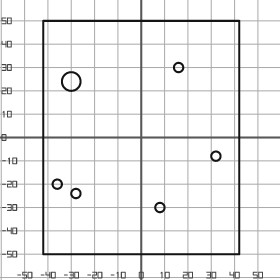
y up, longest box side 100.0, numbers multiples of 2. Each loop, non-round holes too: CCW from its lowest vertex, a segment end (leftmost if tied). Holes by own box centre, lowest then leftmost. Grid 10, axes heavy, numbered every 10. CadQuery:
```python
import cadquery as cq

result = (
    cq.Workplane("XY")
    .moveTo(-42.0, -50.0)
    .lineTo(42.0, -50.0)
    .lineTo(42.0, 50.0)
    .lineTo(-42.0, 50.0)
    .close()
    .moveTo(8.0, -30.0)
    .circle(2.0)
    .moveTo(-28.0, -24.0)
    .circle(2.0)
    .moveTo(-36.0, -20.0)
    .circle(2.0)
    .moveTo(32.0, -8.0)
    .circle(2.0)
    .moveTo(-30.0, 24.0)
    .circle(4.0)
    .moveTo(16.0, 30.0)
    .circle(2.0)
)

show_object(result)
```